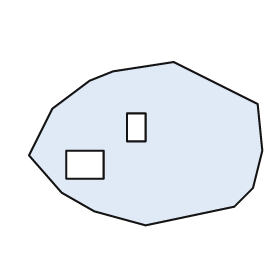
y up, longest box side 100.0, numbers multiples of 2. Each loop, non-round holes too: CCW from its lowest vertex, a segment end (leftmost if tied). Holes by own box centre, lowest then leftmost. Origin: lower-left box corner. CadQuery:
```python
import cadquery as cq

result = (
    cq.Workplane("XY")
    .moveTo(50.0, 0.0)
    .lineTo(88.0, 8.0)
    .lineTo(96.0, 16.0)
    .lineTo(100.0, 32.0)
    .lineTo(98.0, 52.0)
    .lineTo(62.0, 70.0)
    .lineTo(36.0, 66.0)
    .lineTo(26.0, 62.0)
    .lineTo(10.0, 50.0)
    .lineTo(0.0, 30.0)
    .lineTo(14.0, 14.0)
    .lineTo(28.0, 6.0)
    .close()
    .moveTo(16.0, 20.0)
    .lineTo(32.0, 20.0)
    .lineTo(32.0, 32.0)
    .lineTo(16.0, 32.0)
    .close()
    .moveTo(42.0, 36.0)
    .lineTo(50.0, 36.0)
    .lineTo(50.0, 48.0)
    .lineTo(42.0, 48.0)
    .close()
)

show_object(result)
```